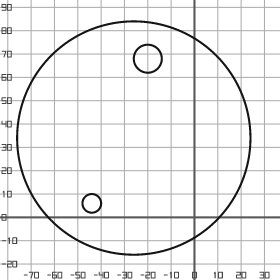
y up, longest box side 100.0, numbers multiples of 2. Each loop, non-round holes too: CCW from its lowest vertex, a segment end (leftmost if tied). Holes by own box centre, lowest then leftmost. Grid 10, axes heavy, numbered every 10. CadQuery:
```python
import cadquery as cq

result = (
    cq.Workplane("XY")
    .moveTo(-26.0, 34.0)
    .circle(50.0)
    .moveTo(-44.0, 6.0)
    .circle(4.0)
    .moveTo(-20.0, 68.0)
    .circle(6.0)
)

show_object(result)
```